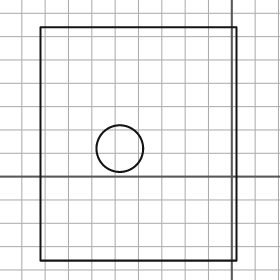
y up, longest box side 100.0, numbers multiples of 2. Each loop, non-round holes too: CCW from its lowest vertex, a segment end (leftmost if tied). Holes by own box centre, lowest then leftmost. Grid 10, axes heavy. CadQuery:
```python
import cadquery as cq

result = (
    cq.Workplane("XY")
    .moveTo(-82.0, -36.0)
    .lineTo(2.0, -36.0)
    .lineTo(2.0, 64.0)
    .lineTo(-82.0, 64.0)
    .close()
    .moveTo(-48.0, 12.0)
    .circle(10.0)
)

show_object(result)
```